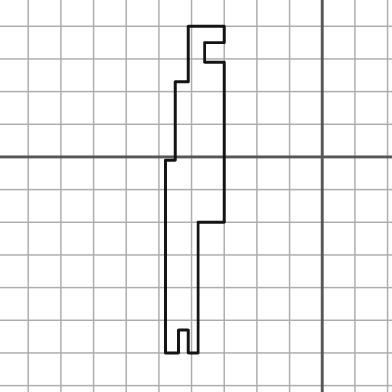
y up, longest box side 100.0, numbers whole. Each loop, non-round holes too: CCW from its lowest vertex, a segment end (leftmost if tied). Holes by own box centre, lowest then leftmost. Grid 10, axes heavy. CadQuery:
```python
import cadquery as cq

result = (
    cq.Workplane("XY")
    .moveTo(-48.0, -60.0)
    .lineTo(-44.0, -60.0)
    .lineTo(-44.0, -53.0)
    .lineTo(-41.0, -53.0)
    .lineTo(-41.0, -60.0)
    .lineTo(-38.0, -60.0)
    .lineTo(-38.0, -20.0)
    .lineTo(-30.0, -20.0)
    .lineTo(-30.0, 29.0)
    .lineTo(-36.0, 29.0)
    .lineTo(-36.0, 35.0)
    .lineTo(-30.0, 35.0)
    .lineTo(-30.0, 40.0)
    .lineTo(-41.0, 40.0)
    .lineTo(-41.0, 23.0)
    .lineTo(-45.0, 23.0)
    .lineTo(-45.0, -1.0)
    .lineTo(-48.0, -1.0)
    .close()
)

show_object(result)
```